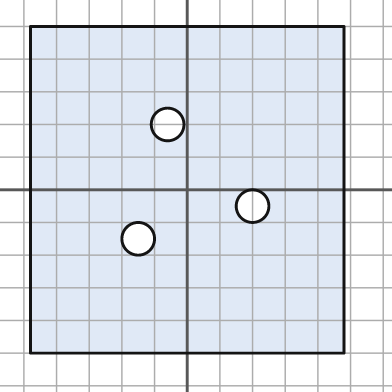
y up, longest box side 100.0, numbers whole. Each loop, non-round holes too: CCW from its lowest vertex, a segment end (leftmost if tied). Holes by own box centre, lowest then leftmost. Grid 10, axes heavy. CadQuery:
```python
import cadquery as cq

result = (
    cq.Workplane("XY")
    .moveTo(-48.0, -50.0)
    .lineTo(48.0, -50.0)
    .lineTo(48.0, 50.0)
    .lineTo(-48.0, 50.0)
    .close()
    .moveTo(-15.0, -15.0)
    .circle(5.0)
    .moveTo(20.0, -5.0)
    .circle(5.0)
    .moveTo(-6.0, 20.0)
    .circle(5.0)
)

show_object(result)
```